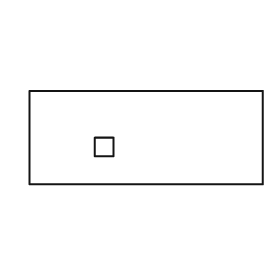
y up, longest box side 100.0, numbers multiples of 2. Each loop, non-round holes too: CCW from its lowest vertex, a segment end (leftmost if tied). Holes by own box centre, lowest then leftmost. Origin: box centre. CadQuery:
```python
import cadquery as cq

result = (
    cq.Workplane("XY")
    .moveTo(-50.0, -20.0)
    .lineTo(50.0, -20.0)
    .lineTo(50.0, 20.0)
    .lineTo(-50.0, 20.0)
    .close()
    .moveTo(-22.0, -8.0)
    .lineTo(-14.0, -8.0)
    .lineTo(-14.0, 0.0)
    .lineTo(-22.0, 0.0)
    .close()
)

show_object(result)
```